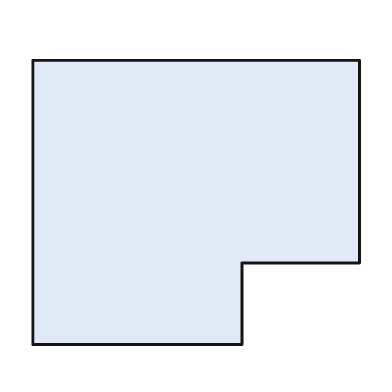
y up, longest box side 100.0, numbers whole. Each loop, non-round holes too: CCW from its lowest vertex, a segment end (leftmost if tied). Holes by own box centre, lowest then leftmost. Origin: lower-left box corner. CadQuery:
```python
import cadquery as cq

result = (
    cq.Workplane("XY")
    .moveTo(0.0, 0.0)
    .lineTo(64.0, 0.0)
    .lineTo(64.0, 25.0)
    .lineTo(100.0, 25.0)
    .lineTo(100.0, 87.0)
    .lineTo(0.0, 87.0)
    .close()
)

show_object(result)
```